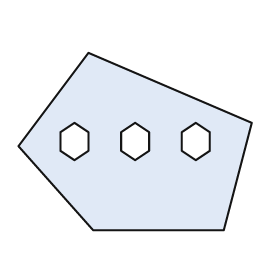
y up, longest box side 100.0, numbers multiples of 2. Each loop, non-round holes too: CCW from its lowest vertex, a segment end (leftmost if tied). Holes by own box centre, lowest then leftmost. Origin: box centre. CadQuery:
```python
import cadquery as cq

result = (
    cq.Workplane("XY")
    .moveTo(-18.0, -38.0)
    .lineTo(38.0, -38.0)
    .lineTo(50.0, 8.0)
    .lineTo(-20.0, 38.0)
    .lineTo(-50.0, -2.0)
    .close()
    .moveTo(-26.0, -8.0)
    .lineTo(-20.0, -4.0)
    .lineTo(-20.0, 4.0)
    .lineTo(-26.0, 8.0)
    .lineTo(-32.0, 4.0)
    .lineTo(-32.0, -4.0)
    .close()
    .moveTo(0.0, -8.0)
    .lineTo(6.0, -4.0)
    .lineTo(6.0, 4.0)
    .lineTo(0.0, 8.0)
    .lineTo(-6.0, 4.0)
    .lineTo(-6.0, -4.0)
    .close()
    .moveTo(26.0, -8.0)
    .lineTo(32.0, -4.0)
    .lineTo(32.0, 4.0)
    .lineTo(26.0, 8.0)
    .lineTo(20.0, 4.0)
    .lineTo(20.0, -4.0)
    .close()
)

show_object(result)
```